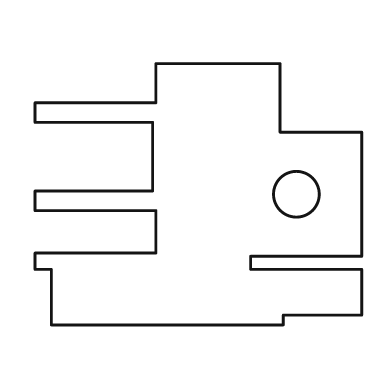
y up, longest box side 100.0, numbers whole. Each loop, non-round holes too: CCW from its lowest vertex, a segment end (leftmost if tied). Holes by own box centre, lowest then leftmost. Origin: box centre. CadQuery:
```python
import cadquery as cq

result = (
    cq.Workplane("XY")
    .moveTo(-45.0, -40.0)
    .lineTo(26.0, -40.0)
    .lineTo(26.0, -37.0)
    .lineTo(50.0, -37.0)
    .lineTo(50.0, -23.0)
    .lineTo(16.0, -23.0)
    .lineTo(16.0, -19.0)
    .lineTo(50.0, -19.0)
    .lineTo(50.0, 19.0)
    .lineTo(25.0, 19.0)
    .lineTo(25.0, 40.0)
    .lineTo(-13.0, 40.0)
    .lineTo(-13.0, 28.0)
    .lineTo(-50.0, 28.0)
    .lineTo(-50.0, 22.0)
    .lineTo(-14.0, 22.0)
    .lineTo(-14.0, 1.0)
    .lineTo(-50.0, 1.0)
    .lineTo(-50.0, -5.0)
    .lineTo(-13.0, -5.0)
    .lineTo(-13.0, -18.0)
    .lineTo(-50.0, -18.0)
    .lineTo(-50.0, -23.0)
    .lineTo(-45.0, -23.0)
    .close()
    .moveTo(30.0, 0.0)
    .circle(7.0)
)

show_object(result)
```